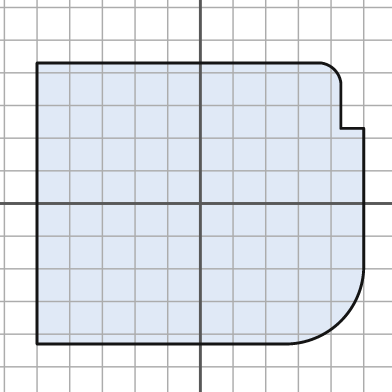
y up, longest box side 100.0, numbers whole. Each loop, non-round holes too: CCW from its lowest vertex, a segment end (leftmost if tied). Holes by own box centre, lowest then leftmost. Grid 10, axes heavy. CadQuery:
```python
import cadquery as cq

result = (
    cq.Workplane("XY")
    .moveTo(-50.0, -43.0)
    .lineTo(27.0, -43.0)
    .threePointArc((43.0, -36.0), (50.0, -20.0))
    .lineTo(50.0, 23.0)
    .lineTo(43.0, 23.0)
    .lineTo(43.0, 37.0)
    .threePointArc((41.0, 41.0), (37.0, 43.0))
    .lineTo(-50.0, 43.0)
    .close()
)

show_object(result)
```